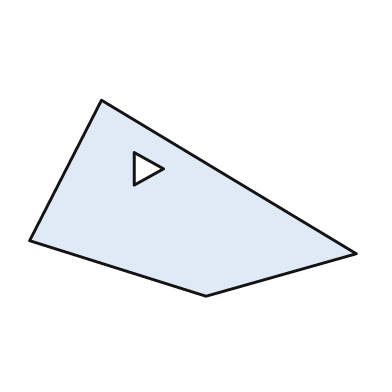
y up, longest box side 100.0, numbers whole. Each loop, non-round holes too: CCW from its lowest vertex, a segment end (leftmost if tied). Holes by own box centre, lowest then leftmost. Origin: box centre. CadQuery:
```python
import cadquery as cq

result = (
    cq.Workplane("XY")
    .moveTo(4.0, -30.0)
    .lineTo(50.0, -17.0)
    .lineTo(-28.0, 30.0)
    .lineTo(-50.0, -13.0)
    .close()
    .moveTo(-18.0, 4.0)
    .lineTo(-9.0, 9.0)
    .lineTo(-18.0, 14.0)
    .close()
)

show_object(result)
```